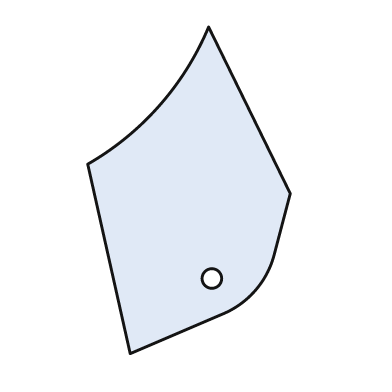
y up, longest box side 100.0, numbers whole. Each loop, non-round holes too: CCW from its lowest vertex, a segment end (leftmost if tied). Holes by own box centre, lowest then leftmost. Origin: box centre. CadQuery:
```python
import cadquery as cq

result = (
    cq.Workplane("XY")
    .moveTo(-18.0, -50.0)
    .lineTo(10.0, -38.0)
    .threePointArc((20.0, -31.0), (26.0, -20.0))
    .lineTo(31.0, -1.0)
    .lineTo(6.0, 50.0)
    .threePointArc((-9.0, 26.0), (-31.0, 8.0))
    .close()
    .moveTo(7.0, -27.0)
    .circle(3.0)
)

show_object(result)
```